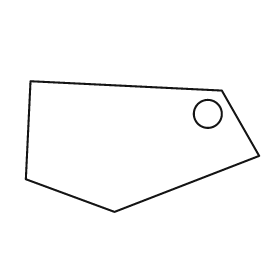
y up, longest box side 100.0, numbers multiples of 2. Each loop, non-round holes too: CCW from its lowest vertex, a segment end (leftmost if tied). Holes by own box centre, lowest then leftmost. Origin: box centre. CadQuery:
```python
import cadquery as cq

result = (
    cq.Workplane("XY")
    .moveTo(-12.0, -28.0)
    .lineTo(50.0, -4.0)
    .lineTo(34.0, 24.0)
    .lineTo(-48.0, 28.0)
    .lineTo(-50.0, -14.0)
    .close()
    .moveTo(28.0, 14.0)
    .circle(6.0)
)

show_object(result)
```